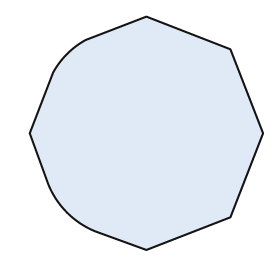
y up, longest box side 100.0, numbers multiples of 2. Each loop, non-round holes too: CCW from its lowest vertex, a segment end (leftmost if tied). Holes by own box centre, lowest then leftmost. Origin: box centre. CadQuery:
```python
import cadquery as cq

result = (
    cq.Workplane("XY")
    .moveTo(0.0, -50.0)
    .lineTo(36.0, -36.0)
    .lineTo(50.0, 0.0)
    .lineTo(36.0, 36.0)
    .lineTo(0.0, 50.0)
    .lineTo(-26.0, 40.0)
    .threePointArc((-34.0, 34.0), (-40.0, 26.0))
    .lineTo(-50.0, 0.0)
    .lineTo(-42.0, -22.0)
    .threePointArc((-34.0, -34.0), (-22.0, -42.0))
    .close()
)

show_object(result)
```